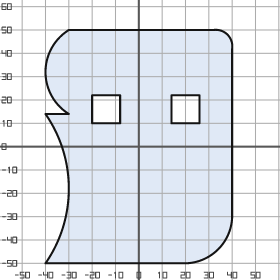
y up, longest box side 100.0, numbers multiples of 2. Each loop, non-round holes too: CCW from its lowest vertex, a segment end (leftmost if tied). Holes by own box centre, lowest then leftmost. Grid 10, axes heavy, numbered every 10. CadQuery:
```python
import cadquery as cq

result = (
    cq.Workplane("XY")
    .moveTo(-40.0, -50.0)
    .lineTo(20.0, -50.0)
    .threePointArc((34.0, -44.0), (40.0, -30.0))
    .lineTo(40.0, 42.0)
    .threePointArc((38.0, 48.0), (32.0, 50.0))
    .lineTo(-30.0, 50.0)
    .threePointArc((-40.0, 32.0), (-30.0, 14.0))
    .lineTo(-40.0, 14.0)
    .threePointArc((-30.0, -18.0), (-40.0, -50.0))
    .close()
    .moveTo(-20.0, 10.0)
    .lineTo(-8.0, 10.0)
    .lineTo(-8.0, 22.0)
    .lineTo(-20.0, 22.0)
    .close()
    .moveTo(14.0, 10.0)
    .lineTo(26.0, 10.0)
    .lineTo(26.0, 22.0)
    .lineTo(14.0, 22.0)
    .close()
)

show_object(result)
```